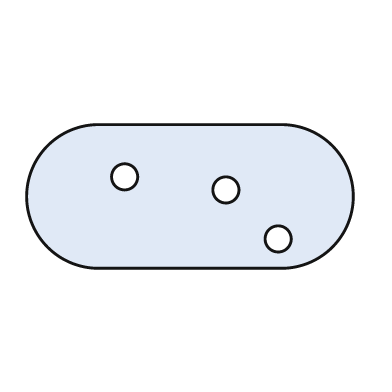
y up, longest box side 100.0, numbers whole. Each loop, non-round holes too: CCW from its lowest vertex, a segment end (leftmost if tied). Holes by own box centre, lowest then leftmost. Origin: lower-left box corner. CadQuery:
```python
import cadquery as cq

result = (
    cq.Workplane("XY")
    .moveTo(22.0, 0.0)
    .lineTo(78.0, 0.0)
    .threePointArc((100.0, 22.0), (78.0, 44.0))
    .lineTo(22.0, 44.0)
    .threePointArc((0.0, 22.0), (22.0, 0.0))
    .close()
    .moveTo(77.0, 9.0)
    .circle(4.0)
    .moveTo(61.0, 24.0)
    .circle(4.0)
    .moveTo(30.0, 28.0)
    .circle(4.0)
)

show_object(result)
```